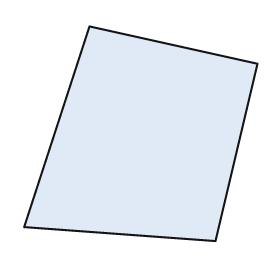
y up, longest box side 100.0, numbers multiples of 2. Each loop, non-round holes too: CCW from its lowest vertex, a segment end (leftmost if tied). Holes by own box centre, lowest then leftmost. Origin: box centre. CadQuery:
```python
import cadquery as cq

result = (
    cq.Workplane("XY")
    .moveTo(32.0, -46.0)
    .lineTo(50.0, 30.0)
    .lineTo(-22.0, 46.0)
    .lineTo(-50.0, -40.0)
    .close()
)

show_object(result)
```